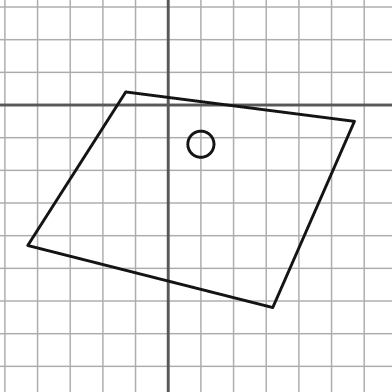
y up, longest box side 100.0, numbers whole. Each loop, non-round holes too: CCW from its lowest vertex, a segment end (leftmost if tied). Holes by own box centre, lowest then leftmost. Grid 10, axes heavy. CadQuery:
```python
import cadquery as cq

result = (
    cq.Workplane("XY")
    .moveTo(32.0, -62.0)
    .lineTo(57.0, -5.0)
    .lineTo(-13.0, 4.0)
    .lineTo(-43.0, -43.0)
    .close()
    .moveTo(10.0, -12.0)
    .circle(4.0)
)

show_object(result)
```